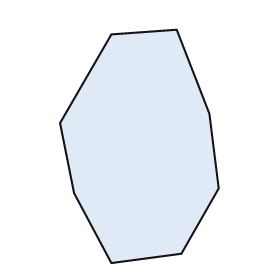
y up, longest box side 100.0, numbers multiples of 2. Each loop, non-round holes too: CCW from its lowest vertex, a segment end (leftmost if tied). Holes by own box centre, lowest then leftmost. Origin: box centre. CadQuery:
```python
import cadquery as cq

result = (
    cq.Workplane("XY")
    .moveTo(-12.0, -50.0)
    .lineTo(18.0, -46.0)
    .lineTo(34.0, -18.0)
    .lineTo(30.0, 14.0)
    .lineTo(16.0, 50.0)
    .lineTo(-12.0, 48.0)
    .lineTo(-34.0, 10.0)
    .lineTo(-28.0, -20.0)
    .close()
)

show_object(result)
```